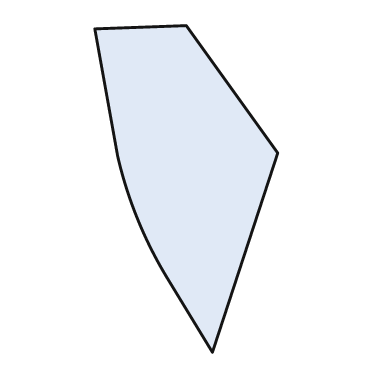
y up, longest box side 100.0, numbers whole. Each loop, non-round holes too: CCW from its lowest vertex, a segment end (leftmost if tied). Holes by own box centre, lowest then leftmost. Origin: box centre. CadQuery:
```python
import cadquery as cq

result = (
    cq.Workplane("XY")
    .moveTo(8.0, -50.0)
    .lineTo(28.0, 11.0)
    .lineTo(0.0, 50.0)
    .lineTo(-28.0, 49.0)
    .lineTo(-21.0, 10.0)
    .threePointArc((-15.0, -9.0), (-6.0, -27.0))
    .close()
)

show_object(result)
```